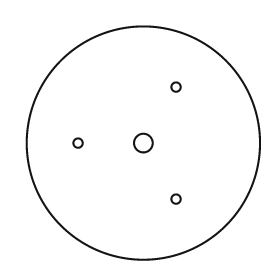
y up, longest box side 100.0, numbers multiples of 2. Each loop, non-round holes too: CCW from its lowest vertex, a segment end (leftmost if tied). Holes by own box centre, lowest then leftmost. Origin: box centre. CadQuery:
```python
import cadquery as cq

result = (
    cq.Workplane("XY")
    .moveTo(0.0, 0.0)
    .circle(50.0)
    .moveTo(14.0, -24.0)
    .circle(2.0)
    .moveTo(-28.0, 0.0)
    .circle(2.0)
    .moveTo(0.0, 0.0)
    .circle(4.0)
    .moveTo(14.0, 24.0)
    .circle(2.0)
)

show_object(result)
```